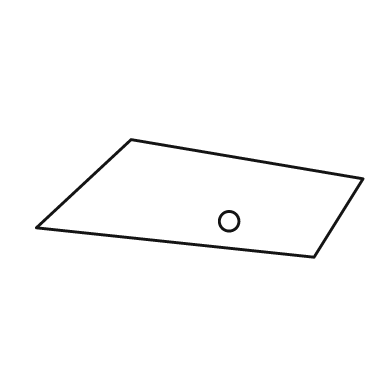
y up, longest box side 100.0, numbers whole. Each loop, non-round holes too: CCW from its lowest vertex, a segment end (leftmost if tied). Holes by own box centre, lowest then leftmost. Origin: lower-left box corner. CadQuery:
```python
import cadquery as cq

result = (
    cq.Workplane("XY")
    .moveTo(85.0, 0.0)
    .lineTo(100.0, 24.0)
    .lineTo(29.0, 36.0)
    .lineTo(0.0, 9.0)
    .close()
    .moveTo(59.0, 11.0)
    .circle(3.0)
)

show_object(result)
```